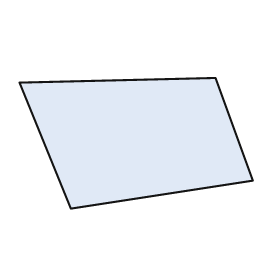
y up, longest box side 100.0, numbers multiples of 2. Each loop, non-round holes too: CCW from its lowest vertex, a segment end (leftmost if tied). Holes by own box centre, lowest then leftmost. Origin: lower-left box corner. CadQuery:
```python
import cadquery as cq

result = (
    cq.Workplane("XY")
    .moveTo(22.0, 0.0)
    .lineTo(100.0, 12.0)
    .lineTo(84.0, 56.0)
    .lineTo(0.0, 54.0)
    .close()
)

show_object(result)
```